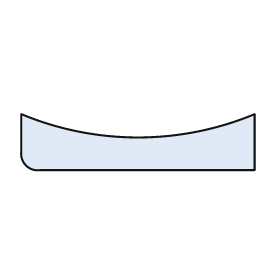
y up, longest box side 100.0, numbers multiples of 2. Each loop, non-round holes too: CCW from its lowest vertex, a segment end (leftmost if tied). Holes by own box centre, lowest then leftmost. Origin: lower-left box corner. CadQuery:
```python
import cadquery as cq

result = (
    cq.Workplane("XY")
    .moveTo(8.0, 0.0)
    .lineTo(100.0, 0.0)
    .lineTo(100.0, 24.0)
    .threePointArc((50.0, 14.0), (0.0, 24.0))
    .lineTo(0.0, 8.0)
    .threePointArc((2.0, 2.0), (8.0, 0.0))
    .close()
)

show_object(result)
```